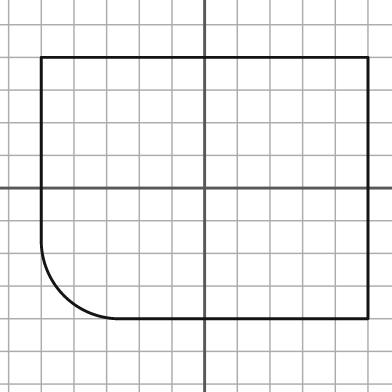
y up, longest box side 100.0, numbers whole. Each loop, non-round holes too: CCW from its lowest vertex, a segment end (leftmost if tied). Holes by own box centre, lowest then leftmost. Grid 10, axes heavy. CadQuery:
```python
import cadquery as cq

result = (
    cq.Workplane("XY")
    .moveTo(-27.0, -40.0)
    .lineTo(50.0, -40.0)
    .lineTo(50.0, 40.0)
    .lineTo(-50.0, 40.0)
    .lineTo(-50.0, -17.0)
    .threePointArc((-43.0, -33.0), (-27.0, -40.0))
    .close()
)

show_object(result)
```